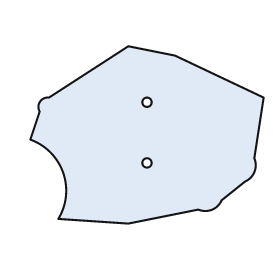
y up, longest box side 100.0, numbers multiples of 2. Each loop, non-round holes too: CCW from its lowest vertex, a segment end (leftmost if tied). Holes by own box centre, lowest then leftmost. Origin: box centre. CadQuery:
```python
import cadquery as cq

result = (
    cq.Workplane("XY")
    .moveTo(-8.0, -38.0)
    .lineTo(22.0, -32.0)
    .threePointArc((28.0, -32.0), (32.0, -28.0))
    .lineTo(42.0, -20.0)
    .threePointArc((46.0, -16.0), (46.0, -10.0))
    .lineTo(50.0, 16.0)
    .lineTo(12.0, 34.0)
    .lineTo(-8.0, 38.0)
    .lineTo(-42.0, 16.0)
    .threePointArc((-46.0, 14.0), (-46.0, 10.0))
    .lineTo(-50.0, -2.0)
    .threePointArc((-36.0, -16.0), (-38.0, -36.0))
    .close()
    .moveTo(0.0, -12.0)
    .circle(2.0)
    .moveTo(0.0, 14.0)
    .circle(2.0)
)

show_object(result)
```